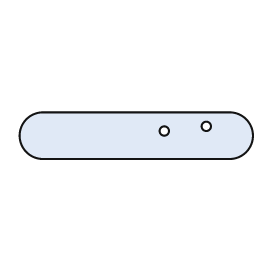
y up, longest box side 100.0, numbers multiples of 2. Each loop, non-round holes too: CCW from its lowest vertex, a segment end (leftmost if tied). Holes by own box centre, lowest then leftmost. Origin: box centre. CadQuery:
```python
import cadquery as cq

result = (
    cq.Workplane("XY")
    .moveTo(-40.0, -10.0)
    .lineTo(40.0, -10.0)
    .threePointArc((50.0, 0.0), (40.0, 10.0))
    .lineTo(-40.0, 10.0)
    .threePointArc((-50.0, 0.0), (-40.0, -10.0))
    .close()
    .moveTo(12.0, 2.0)
    .circle(2.0)
    .moveTo(30.0, 4.0)
    .circle(2.0)
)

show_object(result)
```